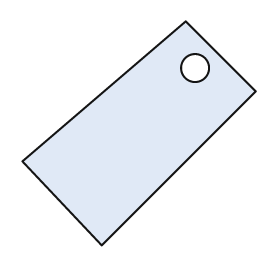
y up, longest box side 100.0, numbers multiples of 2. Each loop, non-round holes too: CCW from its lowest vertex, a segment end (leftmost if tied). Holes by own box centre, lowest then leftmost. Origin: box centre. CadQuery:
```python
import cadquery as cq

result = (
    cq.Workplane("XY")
    .moveTo(-16.0, -48.0)
    .lineTo(50.0, 18.0)
    .lineTo(20.0, 48.0)
    .lineTo(-50.0, -12.0)
    .close()
    .moveTo(24.0, 28.0)
    .circle(6.0)
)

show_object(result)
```